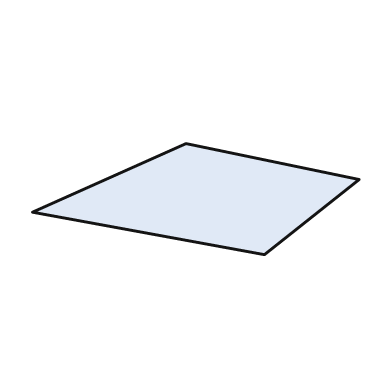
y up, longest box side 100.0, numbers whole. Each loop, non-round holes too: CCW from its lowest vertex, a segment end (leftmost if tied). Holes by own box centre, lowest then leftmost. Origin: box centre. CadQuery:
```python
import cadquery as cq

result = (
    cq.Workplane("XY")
    .moveTo(21.0, -17.0)
    .lineTo(50.0, 6.0)
    .lineTo(-3.0, 17.0)
    .lineTo(-50.0, -4.0)
    .close()
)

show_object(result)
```